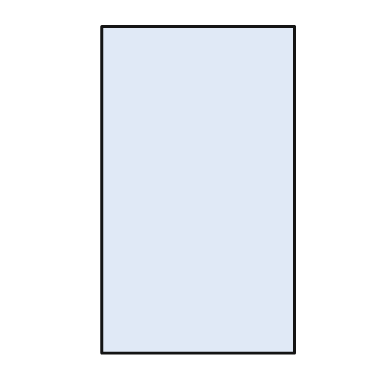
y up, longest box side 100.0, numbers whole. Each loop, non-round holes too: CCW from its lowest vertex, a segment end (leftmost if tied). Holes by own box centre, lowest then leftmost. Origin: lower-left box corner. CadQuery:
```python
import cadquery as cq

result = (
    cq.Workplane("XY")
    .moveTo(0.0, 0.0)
    .lineTo(59.0, 0.0)
    .lineTo(59.0, 100.0)
    .lineTo(0.0, 100.0)
    .close()
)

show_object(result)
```